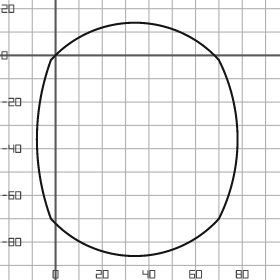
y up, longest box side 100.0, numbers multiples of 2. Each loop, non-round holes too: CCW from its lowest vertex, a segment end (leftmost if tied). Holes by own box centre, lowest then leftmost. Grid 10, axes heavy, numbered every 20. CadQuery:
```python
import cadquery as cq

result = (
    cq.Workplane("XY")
    .moveTo(-2.0, -70.0)
    .threePointArc((34.0, -86.0), (70.0, -70.0))
    .threePointArc((78.0, -36.0), (70.0, -2.0))
    .threePointArc((34.0, 14.0), (-2.0, -2.0))
    .threePointArc((-8.0, -36.0), (-2.0, -70.0))
    .close()
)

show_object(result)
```